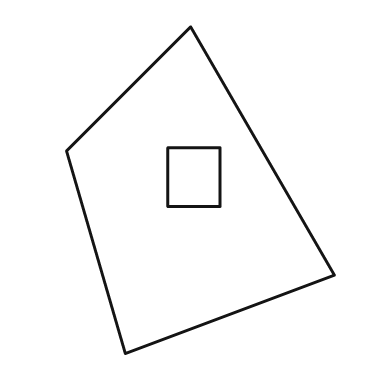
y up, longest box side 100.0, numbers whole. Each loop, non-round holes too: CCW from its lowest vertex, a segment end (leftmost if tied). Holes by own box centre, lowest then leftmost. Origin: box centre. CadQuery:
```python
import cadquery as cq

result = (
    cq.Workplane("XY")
    .moveTo(-23.0, -50.0)
    .lineTo(41.0, -26.0)
    .lineTo(-3.0, 50.0)
    .lineTo(-41.0, 12.0)
    .close()
    .moveTo(-10.0, -5.0)
    .lineTo(6.0, -5.0)
    .lineTo(6.0, 13.0)
    .lineTo(-10.0, 13.0)
    .close()
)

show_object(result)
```